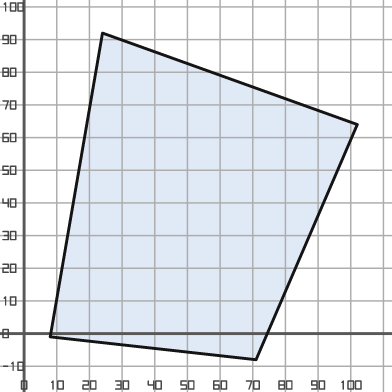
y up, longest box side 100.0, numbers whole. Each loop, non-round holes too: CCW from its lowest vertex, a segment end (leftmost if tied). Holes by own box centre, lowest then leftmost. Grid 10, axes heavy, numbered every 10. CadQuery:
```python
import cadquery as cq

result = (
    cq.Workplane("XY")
    .moveTo(71.0, -8.0)
    .lineTo(102.0, 64.0)
    .lineTo(24.0, 92.0)
    .lineTo(8.0, -1.0)
    .close()
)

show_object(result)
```